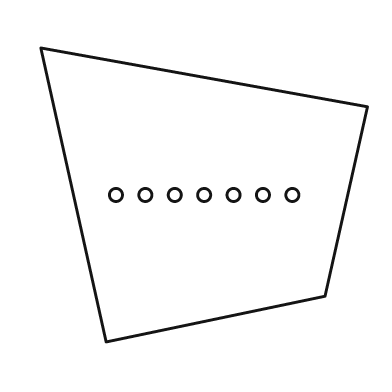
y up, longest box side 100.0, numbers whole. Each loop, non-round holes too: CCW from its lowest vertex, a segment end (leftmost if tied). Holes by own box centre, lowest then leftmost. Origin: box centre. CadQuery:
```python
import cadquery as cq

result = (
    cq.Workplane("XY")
    .moveTo(-30.0, -45.0)
    .lineTo(37.0, -31.0)
    .lineTo(50.0, 27.0)
    .lineTo(-50.0, 45.0)
    .close()
    .moveTo(-27.0, 0.0)
    .circle(2.0)
    .moveTo(-18.0, 0.0)
    .circle(2.0)
    .moveTo(-9.0, 0.0)
    .circle(2.0)
    .moveTo(0.0, 0.0)
    .circle(2.0)
    .moveTo(9.0, 0.0)
    .circle(2.0)
    .moveTo(18.0, 0.0)
    .circle(2.0)
    .moveTo(27.0, 0.0)
    .circle(2.0)
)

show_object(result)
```